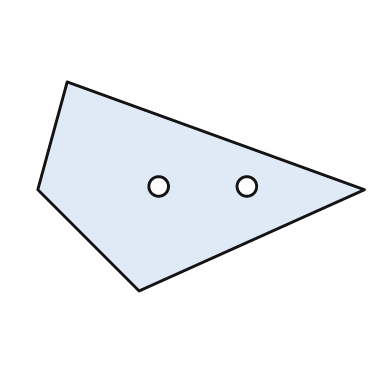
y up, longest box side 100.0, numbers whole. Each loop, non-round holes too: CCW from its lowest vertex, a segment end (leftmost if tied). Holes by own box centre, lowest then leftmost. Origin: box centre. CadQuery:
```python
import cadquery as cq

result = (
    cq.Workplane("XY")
    .moveTo(-19.0, -32.0)
    .lineTo(50.0, -1.0)
    .lineTo(-41.0, 32.0)
    .lineTo(-50.0, -1.0)
    .close()
    .moveTo(-13.0, 0.0)
    .circle(3.0)
    .moveTo(14.0, 0.0)
    .circle(3.0)
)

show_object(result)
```